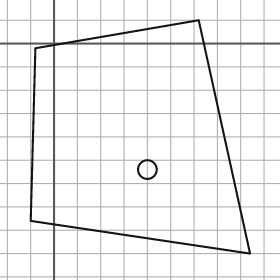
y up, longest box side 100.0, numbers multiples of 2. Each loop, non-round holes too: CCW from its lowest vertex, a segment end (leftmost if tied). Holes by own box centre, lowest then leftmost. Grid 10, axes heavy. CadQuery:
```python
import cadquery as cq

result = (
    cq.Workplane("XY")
    .moveTo(84.0, -90.0)
    .lineTo(62.0, 10.0)
    .lineTo(-8.0, -2.0)
    .lineTo(-10.0, -76.0)
    .close()
    .moveTo(40.0, -54.0)
    .circle(4.0)
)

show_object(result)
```